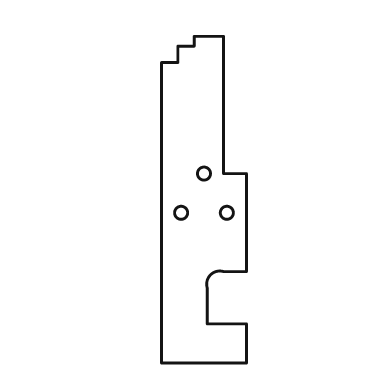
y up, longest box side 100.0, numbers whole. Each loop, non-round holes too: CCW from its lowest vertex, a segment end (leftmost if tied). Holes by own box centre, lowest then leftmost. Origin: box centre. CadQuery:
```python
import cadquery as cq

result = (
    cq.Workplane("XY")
    .moveTo(-13.0, -50.0)
    .lineTo(13.0, -50.0)
    .lineTo(13.0, -38.0)
    .lineTo(1.0, -38.0)
    .lineTo(1.0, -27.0)
    .threePointArc((2.0, -23.0), (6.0, -22.0))
    .lineTo(13.0, -22.0)
    .lineTo(13.0, 8.0)
    .lineTo(6.0, 8.0)
    .lineTo(6.0, 50.0)
    .lineTo(-3.0, 50.0)
    .lineTo(-3.0, 47.0)
    .lineTo(-8.0, 47.0)
    .lineTo(-8.0, 42.0)
    .lineTo(-13.0, 42.0)
    .close()
    .moveTo(-7.0, -4.0)
    .circle(2.0)
    .moveTo(7.0, -4.0)
    .circle(2.0)
    .moveTo(0.0, 8.0)
    .circle(2.0)
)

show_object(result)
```